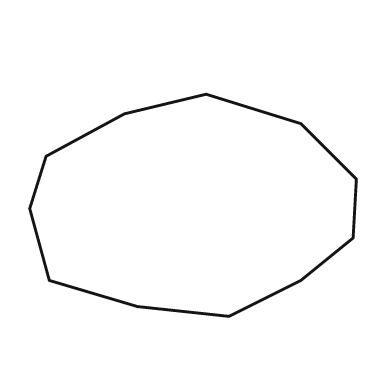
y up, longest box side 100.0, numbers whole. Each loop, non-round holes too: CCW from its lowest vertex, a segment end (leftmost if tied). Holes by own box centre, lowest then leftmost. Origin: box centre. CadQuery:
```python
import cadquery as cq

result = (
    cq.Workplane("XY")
    .moveTo(11.0, -34.0)
    .lineTo(33.0, -23.0)
    .lineTo(49.0, -10.0)
    .lineTo(50.0, 8.0)
    .lineTo(33.0, 25.0)
    .lineTo(4.0, 34.0)
    .lineTo(-21.0, 28.0)
    .lineTo(-45.0, 15.0)
    .lineTo(-50.0, -1.0)
    .lineTo(-44.0, -23.0)
    .lineTo(-17.0, -31.0)
    .close()
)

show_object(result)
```